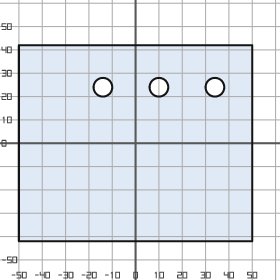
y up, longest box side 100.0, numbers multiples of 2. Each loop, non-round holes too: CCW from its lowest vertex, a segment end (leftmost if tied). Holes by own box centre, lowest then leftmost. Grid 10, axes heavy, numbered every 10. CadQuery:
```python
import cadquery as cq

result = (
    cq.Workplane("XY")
    .moveTo(-50.0, -42.0)
    .lineTo(50.0, -42.0)
    .lineTo(50.0, 42.0)
    .lineTo(-50.0, 42.0)
    .close()
    .moveTo(-14.0, 24.0)
    .circle(4.0)
    .moveTo(10.0, 24.0)
    .circle(4.0)
    .moveTo(34.0, 24.0)
    .circle(4.0)
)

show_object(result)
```